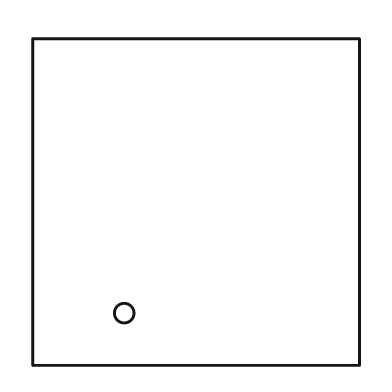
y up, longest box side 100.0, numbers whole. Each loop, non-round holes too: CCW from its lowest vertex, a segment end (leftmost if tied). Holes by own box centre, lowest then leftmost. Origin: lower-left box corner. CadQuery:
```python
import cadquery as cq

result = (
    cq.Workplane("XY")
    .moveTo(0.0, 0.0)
    .lineTo(100.0, 0.0)
    .lineTo(100.0, 100.0)
    .lineTo(0.0, 100.0)
    .close()
    .moveTo(28.0, 16.0)
    .circle(3.0)
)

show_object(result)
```